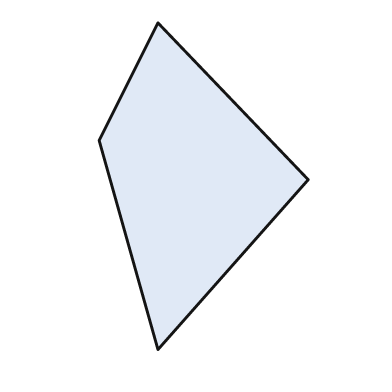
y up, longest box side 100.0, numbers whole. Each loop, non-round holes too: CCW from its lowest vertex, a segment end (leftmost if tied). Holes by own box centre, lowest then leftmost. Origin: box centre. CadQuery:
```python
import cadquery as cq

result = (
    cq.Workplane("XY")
    .moveTo(-14.0, -50.0)
    .lineTo(32.0, 2.0)
    .lineTo(-14.0, 50.0)
    .lineTo(-32.0, 14.0)
    .close()
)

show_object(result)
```